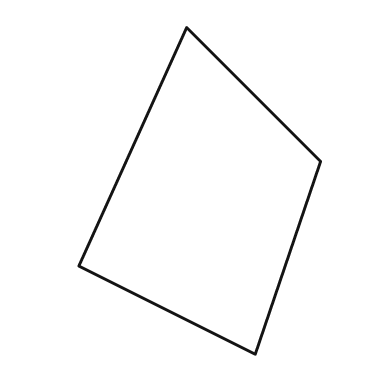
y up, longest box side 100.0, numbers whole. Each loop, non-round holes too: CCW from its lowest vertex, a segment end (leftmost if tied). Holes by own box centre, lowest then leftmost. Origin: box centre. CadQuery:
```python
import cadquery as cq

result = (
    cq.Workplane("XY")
    .moveTo(17.0, -50.0)
    .lineTo(37.0, 9.0)
    .lineTo(-4.0, 50.0)
    .lineTo(-37.0, -23.0)
    .close()
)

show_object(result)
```